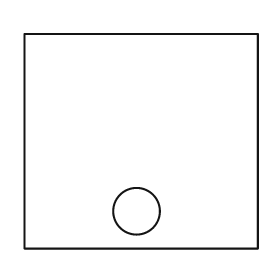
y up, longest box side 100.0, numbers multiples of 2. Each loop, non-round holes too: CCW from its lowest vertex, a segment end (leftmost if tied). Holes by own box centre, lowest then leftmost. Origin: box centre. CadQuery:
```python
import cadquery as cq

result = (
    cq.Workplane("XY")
    .moveTo(-50.0, -46.0)
    .lineTo(50.0, -46.0)
    .lineTo(50.0, 46.0)
    .lineTo(-50.0, 46.0)
    .close()
    .moveTo(-2.0, -30.0)
    .circle(10.0)
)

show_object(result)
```